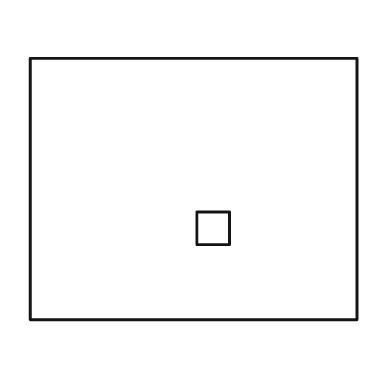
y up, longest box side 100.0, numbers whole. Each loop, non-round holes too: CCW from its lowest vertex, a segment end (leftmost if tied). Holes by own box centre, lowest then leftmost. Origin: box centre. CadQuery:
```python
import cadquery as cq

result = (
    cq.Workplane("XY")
    .moveTo(-50.0, -40.0)
    .lineTo(50.0, -40.0)
    .lineTo(50.0, 40.0)
    .lineTo(-50.0, 40.0)
    .close()
    .moveTo(1.0, -17.0)
    .lineTo(11.0, -17.0)
    .lineTo(11.0, -7.0)
    .lineTo(1.0, -7.0)
    .close()
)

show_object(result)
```